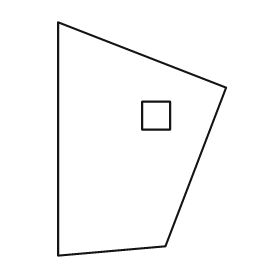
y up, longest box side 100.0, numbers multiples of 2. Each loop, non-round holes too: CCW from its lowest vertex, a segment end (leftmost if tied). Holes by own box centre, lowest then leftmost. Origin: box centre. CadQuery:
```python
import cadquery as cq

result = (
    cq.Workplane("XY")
    .moveTo(-36.0, -50.0)
    .lineTo(10.0, -46.0)
    .lineTo(36.0, 22.0)
    .lineTo(-36.0, 50.0)
    .close()
    .moveTo(0.0, 4.0)
    .lineTo(12.0, 4.0)
    .lineTo(12.0, 16.0)
    .lineTo(0.0, 16.0)
    .close()
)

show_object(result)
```